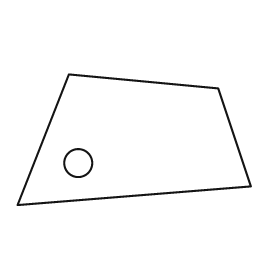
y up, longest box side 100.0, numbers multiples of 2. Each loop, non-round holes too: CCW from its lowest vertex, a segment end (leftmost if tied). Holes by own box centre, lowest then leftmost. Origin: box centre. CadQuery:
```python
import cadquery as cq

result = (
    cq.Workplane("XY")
    .moveTo(-50.0, -28.0)
    .lineTo(50.0, -20.0)
    .lineTo(36.0, 22.0)
    .lineTo(-28.0, 28.0)
    .close()
    .moveTo(-24.0, -10.0)
    .circle(6.0)
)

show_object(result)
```